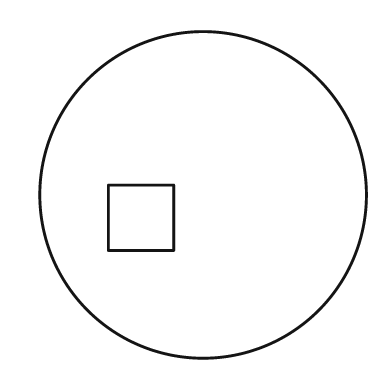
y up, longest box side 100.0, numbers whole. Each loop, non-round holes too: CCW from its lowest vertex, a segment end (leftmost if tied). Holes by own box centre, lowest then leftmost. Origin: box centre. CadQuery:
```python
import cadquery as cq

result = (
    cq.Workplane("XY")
    .moveTo(0.0, 0.0)
    .circle(50.0)
    .moveTo(-29.0, -17.0)
    .lineTo(-9.0, -17.0)
    .lineTo(-9.0, 3.0)
    .lineTo(-29.0, 3.0)
    .close()
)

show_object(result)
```